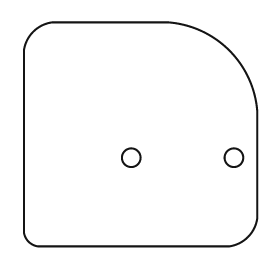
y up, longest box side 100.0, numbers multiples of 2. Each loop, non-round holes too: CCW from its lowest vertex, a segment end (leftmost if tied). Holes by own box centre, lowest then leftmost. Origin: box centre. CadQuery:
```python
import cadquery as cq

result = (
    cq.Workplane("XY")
    .moveTo(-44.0, -48.0)
    .lineTo(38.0, -48.0)
    .threePointArc((46.0, -44.0), (50.0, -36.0))
    .lineTo(50.0, 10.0)
    .threePointArc((38.0, 36.0), (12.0, 48.0))
    .lineTo(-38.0, 48.0)
    .threePointArc((-46.0, 44.0), (-50.0, 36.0))
    .lineTo(-50.0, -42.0)
    .threePointArc((-48.0, -46.0), (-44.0, -48.0))
    .close()
    .moveTo(-4.0, -10.0)
    .circle(4.0)
    .moveTo(40.0, -10.0)
    .circle(4.0)
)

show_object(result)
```